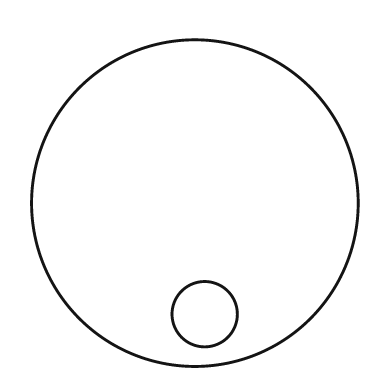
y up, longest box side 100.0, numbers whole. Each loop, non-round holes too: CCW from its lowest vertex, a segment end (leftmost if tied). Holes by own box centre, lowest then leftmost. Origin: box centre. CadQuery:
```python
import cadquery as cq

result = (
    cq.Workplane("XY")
    .moveTo(0.0, 0.0)
    .circle(50.0)
    .moveTo(3.0, -34.0)
    .circle(10.0)
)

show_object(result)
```